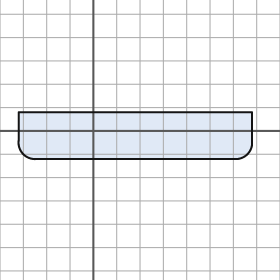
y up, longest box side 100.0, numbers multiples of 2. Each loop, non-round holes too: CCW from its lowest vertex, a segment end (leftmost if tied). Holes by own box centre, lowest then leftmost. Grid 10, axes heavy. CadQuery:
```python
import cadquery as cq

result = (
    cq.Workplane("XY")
    .moveTo(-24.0, -12.0)
    .lineTo(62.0, -12.0)
    .threePointArc((66.0, -10.0), (68.0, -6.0))
    .lineTo(68.0, 8.0)
    .lineTo(-32.0, 8.0)
    .lineTo(-32.0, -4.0)
    .threePointArc((-30.0, -10.0), (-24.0, -12.0))
    .close()
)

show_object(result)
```